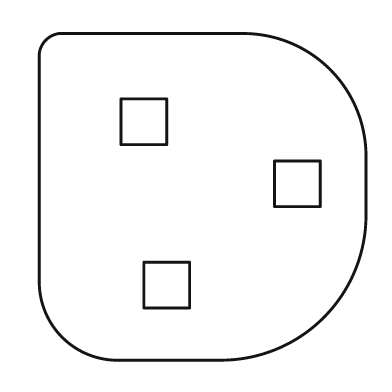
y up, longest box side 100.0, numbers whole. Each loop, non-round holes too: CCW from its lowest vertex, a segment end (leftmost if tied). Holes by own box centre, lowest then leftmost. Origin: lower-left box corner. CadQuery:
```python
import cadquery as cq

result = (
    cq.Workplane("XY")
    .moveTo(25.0, 0.0)
    .lineTo(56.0, 0.0)
    .threePointArc((87.0, 13.0), (100.0, 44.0))
    .lineTo(100.0, 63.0)
    .threePointArc((89.0, 89.0), (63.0, 100.0))
    .lineTo(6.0, 100.0)
    .threePointArc((2.0, 98.0), (0.0, 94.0))
    .lineTo(0.0, 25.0)
    .threePointArc((7.0, 7.0), (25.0, 0.0))
    .close()
    .moveTo(32.0, 16.0)
    .lineTo(46.0, 16.0)
    .lineTo(46.0, 30.0)
    .lineTo(32.0, 30.0)
    .close()
    .moveTo(72.0, 47.0)
    .lineTo(86.0, 47.0)
    .lineTo(86.0, 61.0)
    .lineTo(72.0, 61.0)
    .close()
    .moveTo(25.0, 66.0)
    .lineTo(39.0, 66.0)
    .lineTo(39.0, 80.0)
    .lineTo(25.0, 80.0)
    .close()
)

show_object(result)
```